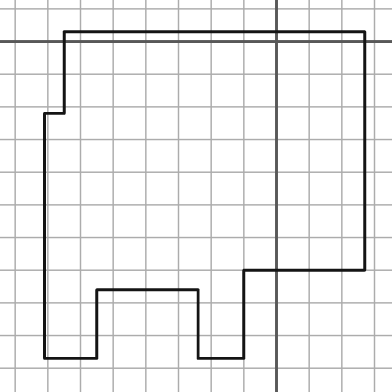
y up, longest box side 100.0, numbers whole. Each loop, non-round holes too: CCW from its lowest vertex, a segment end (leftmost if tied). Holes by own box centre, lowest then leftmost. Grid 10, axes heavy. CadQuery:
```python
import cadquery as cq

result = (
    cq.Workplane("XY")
    .moveTo(-71.0, -97.0)
    .lineTo(-55.0, -97.0)
    .lineTo(-55.0, -76.0)
    .lineTo(-24.0, -76.0)
    .lineTo(-24.0, -97.0)
    .lineTo(-10.0, -97.0)
    .lineTo(-10.0, -70.0)
    .lineTo(27.0, -70.0)
    .lineTo(27.0, 3.0)
    .lineTo(-65.0, 3.0)
    .lineTo(-65.0, -22.0)
    .lineTo(-71.0, -22.0)
    .close()
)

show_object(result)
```